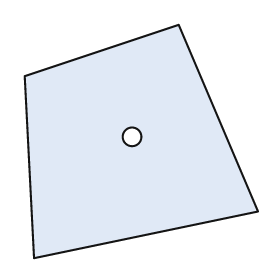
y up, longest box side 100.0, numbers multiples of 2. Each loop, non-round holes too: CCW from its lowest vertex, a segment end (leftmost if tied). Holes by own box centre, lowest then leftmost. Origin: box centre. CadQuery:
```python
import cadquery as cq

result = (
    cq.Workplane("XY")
    .moveTo(-46.0, -50.0)
    .lineTo(50.0, -30.0)
    .lineTo(16.0, 50.0)
    .lineTo(-50.0, 28.0)
    .close()
    .moveTo(-4.0, 2.0)
    .circle(4.0)
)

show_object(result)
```